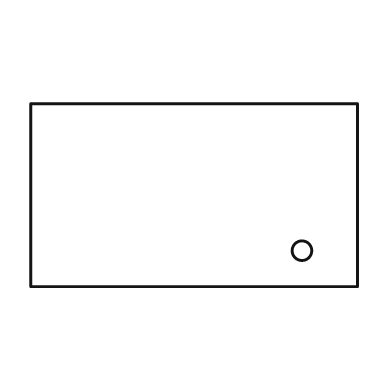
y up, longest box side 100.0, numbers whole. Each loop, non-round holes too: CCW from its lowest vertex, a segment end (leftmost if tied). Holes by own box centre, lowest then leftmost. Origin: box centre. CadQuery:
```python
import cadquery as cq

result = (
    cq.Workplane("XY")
    .moveTo(-50.0, -28.0)
    .lineTo(50.0, -28.0)
    .lineTo(50.0, 28.0)
    .lineTo(-50.0, 28.0)
    .close()
    .moveTo(33.0, -17.0)
    .circle(3.0)
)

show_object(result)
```